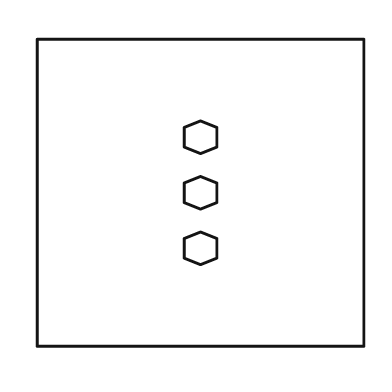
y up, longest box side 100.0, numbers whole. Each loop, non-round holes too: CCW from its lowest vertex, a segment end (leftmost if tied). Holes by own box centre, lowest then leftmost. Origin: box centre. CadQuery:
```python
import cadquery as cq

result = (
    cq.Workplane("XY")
    .moveTo(-50.0, -47.0)
    .lineTo(50.0, -47.0)
    .lineTo(50.0, 47.0)
    .lineTo(-50.0, 47.0)
    .close()
    .moveTo(0.0, -22.0)
    .lineTo(5.0, -20.0)
    .lineTo(5.0, -14.0)
    .lineTo(0.0, -12.0)
    .lineTo(-5.0, -14.0)
    .lineTo(-5.0, -20.0)
    .close()
    .moveTo(0.0, -5.0)
    .lineTo(5.0, -3.0)
    .lineTo(5.0, 3.0)
    .lineTo(0.0, 5.0)
    .lineTo(-5.0, 3.0)
    .lineTo(-5.0, -3.0)
    .close()
    .moveTo(0.0, 12.0)
    .lineTo(5.0, 14.0)
    .lineTo(5.0, 20.0)
    .lineTo(0.0, 22.0)
    .lineTo(-5.0, 20.0)
    .lineTo(-5.0, 14.0)
    .close()
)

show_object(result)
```